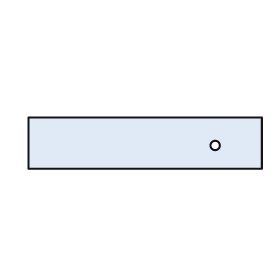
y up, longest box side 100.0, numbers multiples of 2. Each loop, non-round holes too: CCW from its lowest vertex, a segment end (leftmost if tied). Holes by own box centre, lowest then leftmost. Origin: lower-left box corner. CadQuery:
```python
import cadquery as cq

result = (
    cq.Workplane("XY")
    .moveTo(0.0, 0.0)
    .lineTo(100.0, 0.0)
    .lineTo(100.0, 22.0)
    .lineTo(0.0, 22.0)
    .close()
    .moveTo(80.0, 10.0)
    .circle(2.0)
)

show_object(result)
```